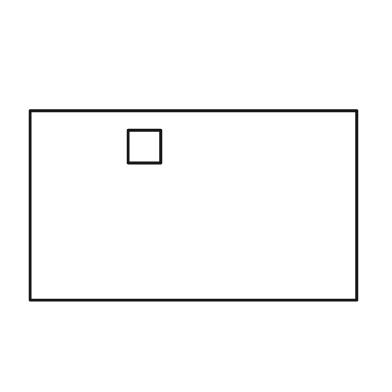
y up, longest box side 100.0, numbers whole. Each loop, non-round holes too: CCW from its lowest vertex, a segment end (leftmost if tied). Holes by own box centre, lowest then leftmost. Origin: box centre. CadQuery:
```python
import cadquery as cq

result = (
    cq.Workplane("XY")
    .moveTo(-50.0, -29.0)
    .lineTo(50.0, -29.0)
    .lineTo(50.0, 29.0)
    .lineTo(-50.0, 29.0)
    .close()
    .moveTo(-20.0, 13.0)
    .lineTo(-10.0, 13.0)
    .lineTo(-10.0, 23.0)
    .lineTo(-20.0, 23.0)
    .close()
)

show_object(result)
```